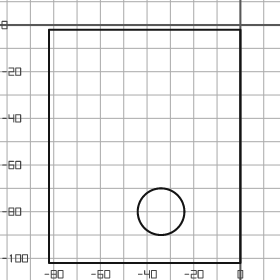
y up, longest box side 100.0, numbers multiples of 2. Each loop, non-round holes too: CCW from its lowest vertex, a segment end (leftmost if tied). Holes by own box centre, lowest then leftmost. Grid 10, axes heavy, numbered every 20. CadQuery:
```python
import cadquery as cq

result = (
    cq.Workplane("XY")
    .moveTo(-82.0, -102.0)
    .lineTo(0.0, -102.0)
    .lineTo(0.0, -2.0)
    .lineTo(-82.0, -2.0)
    .close()
    .moveTo(-34.0, -80.0)
    .circle(10.0)
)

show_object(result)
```